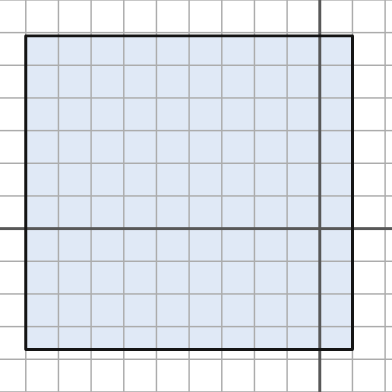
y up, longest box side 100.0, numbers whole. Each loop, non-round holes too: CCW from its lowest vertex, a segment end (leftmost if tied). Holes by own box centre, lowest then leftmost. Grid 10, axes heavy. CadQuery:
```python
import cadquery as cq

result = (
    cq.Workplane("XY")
    .moveTo(-90.0, -37.0)
    .lineTo(10.0, -37.0)
    .lineTo(10.0, 59.0)
    .lineTo(-90.0, 59.0)
    .close()
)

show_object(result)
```